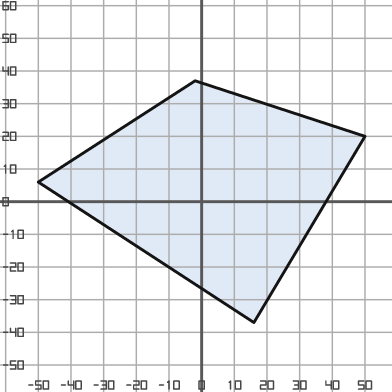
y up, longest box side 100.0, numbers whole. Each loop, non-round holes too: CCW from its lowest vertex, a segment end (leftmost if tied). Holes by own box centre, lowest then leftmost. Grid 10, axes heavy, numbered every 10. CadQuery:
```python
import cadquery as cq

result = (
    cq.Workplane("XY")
    .moveTo(16.0, -37.0)
    .lineTo(50.0, 20.0)
    .lineTo(-2.0, 37.0)
    .lineTo(-50.0, 6.0)
    .close()
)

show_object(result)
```